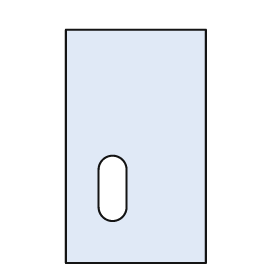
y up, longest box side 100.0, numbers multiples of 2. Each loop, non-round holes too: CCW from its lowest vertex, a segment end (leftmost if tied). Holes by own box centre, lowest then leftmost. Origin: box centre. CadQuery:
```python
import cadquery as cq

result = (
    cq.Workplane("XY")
    .moveTo(-30.0, -50.0)
    .lineTo(30.0, -50.0)
    .lineTo(30.0, 50.0)
    .lineTo(-30.0, 50.0)
    .close()
    .moveTo(-16.0, -26.0)
    .threePointArc((-10.0, -32.0), (-4.0, -26.0))
    .lineTo(-4.0, -10.0)
    .threePointArc((-10.0, -4.0), (-16.0, -10.0))
    .close()
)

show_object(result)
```